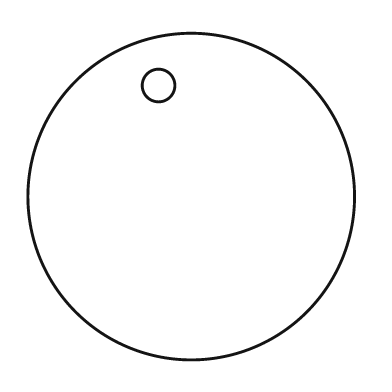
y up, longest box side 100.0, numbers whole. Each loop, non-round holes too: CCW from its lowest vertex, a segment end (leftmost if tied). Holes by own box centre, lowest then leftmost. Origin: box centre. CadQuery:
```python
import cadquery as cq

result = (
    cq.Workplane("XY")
    .moveTo(0.0, 0.0)
    .circle(50.0)
    .moveTo(-10.0, 34.0)
    .circle(5.0)
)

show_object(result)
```